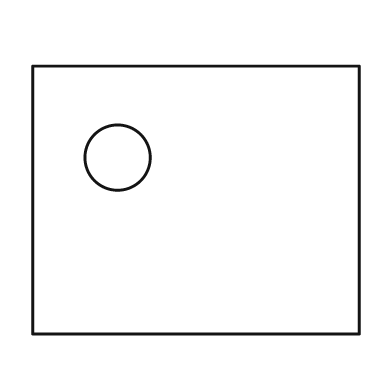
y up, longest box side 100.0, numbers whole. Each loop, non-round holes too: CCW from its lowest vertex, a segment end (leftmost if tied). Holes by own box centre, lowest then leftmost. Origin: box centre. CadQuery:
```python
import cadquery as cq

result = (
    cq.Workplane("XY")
    .moveTo(-50.0, -41.0)
    .lineTo(50.0, -41.0)
    .lineTo(50.0, 41.0)
    .lineTo(-50.0, 41.0)
    .close()
    .moveTo(-24.0, 13.0)
    .circle(10.0)
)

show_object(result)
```